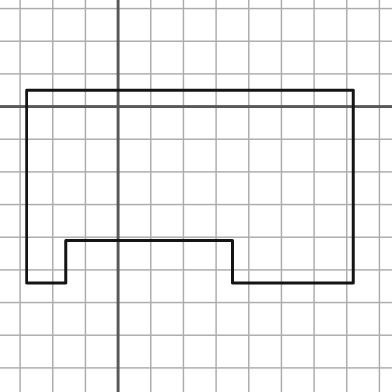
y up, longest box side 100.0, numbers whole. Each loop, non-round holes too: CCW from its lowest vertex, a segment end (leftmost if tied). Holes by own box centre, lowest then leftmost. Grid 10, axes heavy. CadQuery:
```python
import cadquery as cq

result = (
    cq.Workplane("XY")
    .moveTo(-28.0, -54.0)
    .lineTo(-16.0, -54.0)
    .lineTo(-16.0, -41.0)
    .lineTo(35.0, -41.0)
    .lineTo(35.0, -54.0)
    .lineTo(72.0, -54.0)
    .lineTo(72.0, 5.0)
    .lineTo(-28.0, 5.0)
    .close()
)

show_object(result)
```